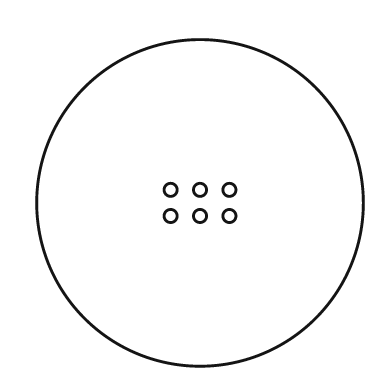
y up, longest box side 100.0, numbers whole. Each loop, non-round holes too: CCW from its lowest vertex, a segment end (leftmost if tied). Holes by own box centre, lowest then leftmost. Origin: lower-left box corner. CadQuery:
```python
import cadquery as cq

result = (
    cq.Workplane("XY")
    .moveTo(50.0, 50.0)
    .circle(50.0)
    .moveTo(41.0, 46.0)
    .circle(2.0)
    .moveTo(50.0, 46.0)
    .circle(2.0)
    .moveTo(59.0, 46.0)
    .circle(2.0)
    .moveTo(41.0, 54.0)
    .circle(2.0)
    .moveTo(50.0, 54.0)
    .circle(2.0)
    .moveTo(59.0, 54.0)
    .circle(2.0)
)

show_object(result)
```